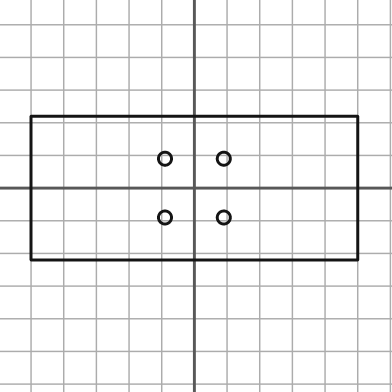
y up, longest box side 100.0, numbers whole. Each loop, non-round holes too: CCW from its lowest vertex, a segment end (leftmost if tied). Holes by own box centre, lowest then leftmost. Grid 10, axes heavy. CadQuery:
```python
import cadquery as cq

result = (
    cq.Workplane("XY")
    .moveTo(-50.0, -22.0)
    .lineTo(50.0, -22.0)
    .lineTo(50.0, 22.0)
    .lineTo(-50.0, 22.0)
    .close()
    .moveTo(-9.0, -9.0)
    .circle(2.0)
    .moveTo(9.0, -9.0)
    .circle(2.0)
    .moveTo(-9.0, 9.0)
    .circle(2.0)
    .moveTo(9.0, 9.0)
    .circle(2.0)
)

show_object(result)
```